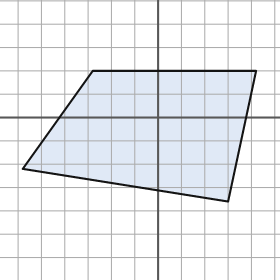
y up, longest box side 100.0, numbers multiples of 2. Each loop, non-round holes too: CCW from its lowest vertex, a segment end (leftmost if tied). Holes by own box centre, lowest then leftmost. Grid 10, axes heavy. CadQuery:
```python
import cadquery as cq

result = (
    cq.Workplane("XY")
    .moveTo(30.0, -36.0)
    .lineTo(42.0, 20.0)
    .lineTo(-28.0, 20.0)
    .lineTo(-58.0, -22.0)
    .close()
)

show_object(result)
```